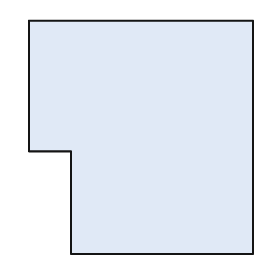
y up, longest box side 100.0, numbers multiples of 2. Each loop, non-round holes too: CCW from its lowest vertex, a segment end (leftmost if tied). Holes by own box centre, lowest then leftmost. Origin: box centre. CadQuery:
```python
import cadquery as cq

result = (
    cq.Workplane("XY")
    .moveTo(-30.0, -50.0)
    .lineTo(48.0, -50.0)
    .lineTo(48.0, 50.0)
    .lineTo(-48.0, 50.0)
    .lineTo(-48.0, -6.0)
    .lineTo(-30.0, -6.0)
    .close()
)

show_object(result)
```